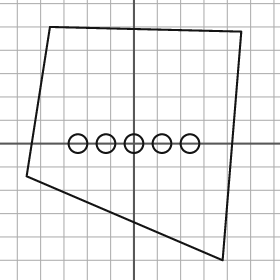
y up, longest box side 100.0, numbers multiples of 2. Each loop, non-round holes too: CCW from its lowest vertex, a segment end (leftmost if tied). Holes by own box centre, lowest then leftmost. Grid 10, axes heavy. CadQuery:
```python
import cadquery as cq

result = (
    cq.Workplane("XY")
    .moveTo(38.0, -50.0)
    .lineTo(46.0, 48.0)
    .lineTo(-36.0, 50.0)
    .lineTo(-46.0, -14.0)
    .close()
    .moveTo(-24.0, 0.0)
    .circle(4.0)
    .moveTo(-12.0, 0.0)
    .circle(4.0)
    .moveTo(0.0, 0.0)
    .circle(4.0)
    .moveTo(12.0, 0.0)
    .circle(4.0)
    .moveTo(24.0, 0.0)
    .circle(4.0)
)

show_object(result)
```